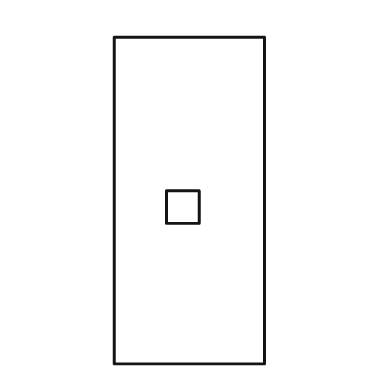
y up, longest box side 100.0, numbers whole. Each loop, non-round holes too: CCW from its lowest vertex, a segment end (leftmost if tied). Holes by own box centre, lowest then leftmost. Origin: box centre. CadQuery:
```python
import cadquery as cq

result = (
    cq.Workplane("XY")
    .moveTo(-23.0, -50.0)
    .lineTo(23.0, -50.0)
    .lineTo(23.0, 50.0)
    .lineTo(-23.0, 50.0)
    .close()
    .moveTo(-7.0, -7.0)
    .lineTo(3.0, -7.0)
    .lineTo(3.0, 3.0)
    .lineTo(-7.0, 3.0)
    .close()
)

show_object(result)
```